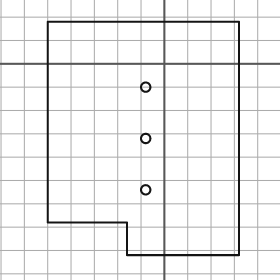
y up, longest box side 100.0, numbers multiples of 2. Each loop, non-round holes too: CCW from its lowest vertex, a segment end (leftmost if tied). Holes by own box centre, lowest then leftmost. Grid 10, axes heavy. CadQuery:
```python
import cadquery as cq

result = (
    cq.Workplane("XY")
    .moveTo(-16.0, -82.0)
    .lineTo(32.0, -82.0)
    .lineTo(32.0, 18.0)
    .lineTo(-50.0, 18.0)
    .lineTo(-50.0, -68.0)
    .lineTo(-16.0, -68.0)
    .close()
    .moveTo(-8.0, -54.0)
    .circle(2.0)
    .moveTo(-8.0, -32.0)
    .circle(2.0)
    .moveTo(-8.0, -10.0)
    .circle(2.0)
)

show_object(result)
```